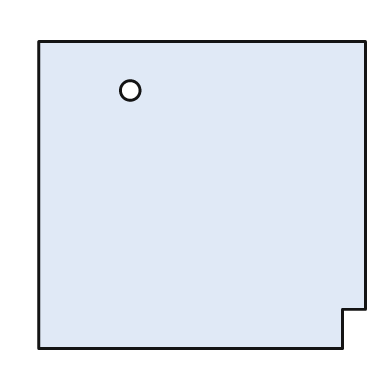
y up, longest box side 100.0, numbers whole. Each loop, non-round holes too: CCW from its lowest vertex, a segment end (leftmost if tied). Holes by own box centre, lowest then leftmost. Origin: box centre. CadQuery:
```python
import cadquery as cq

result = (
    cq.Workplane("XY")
    .moveTo(-50.0, -47.0)
    .lineTo(43.0, -47.0)
    .lineTo(43.0, -35.0)
    .lineTo(50.0, -35.0)
    .lineTo(50.0, 47.0)
    .lineTo(-50.0, 47.0)
    .close()
    .moveTo(-22.0, 32.0)
    .circle(3.0)
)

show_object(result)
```